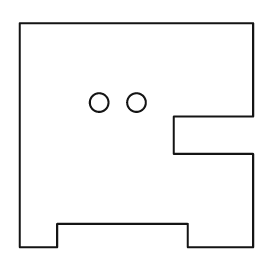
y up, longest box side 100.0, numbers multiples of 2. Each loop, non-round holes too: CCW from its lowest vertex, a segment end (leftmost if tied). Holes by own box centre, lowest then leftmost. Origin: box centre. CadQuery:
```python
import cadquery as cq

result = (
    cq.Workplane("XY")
    .moveTo(-50.0, -48.0)
    .lineTo(-34.0, -48.0)
    .lineTo(-34.0, -38.0)
    .lineTo(22.0, -38.0)
    .lineTo(22.0, -48.0)
    .lineTo(50.0, -48.0)
    .lineTo(50.0, -8.0)
    .lineTo(16.0, -8.0)
    .lineTo(16.0, 8.0)
    .lineTo(50.0, 8.0)
    .lineTo(50.0, 48.0)
    .lineTo(-50.0, 48.0)
    .close()
    .moveTo(-16.0, 14.0)
    .circle(4.0)
    .moveTo(0.0, 14.0)
    .circle(4.0)
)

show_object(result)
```